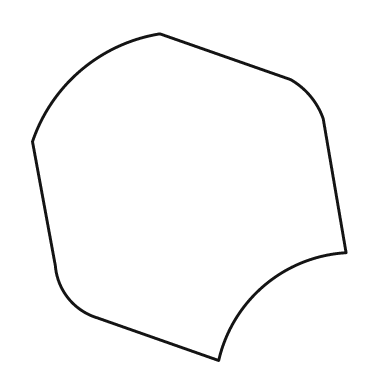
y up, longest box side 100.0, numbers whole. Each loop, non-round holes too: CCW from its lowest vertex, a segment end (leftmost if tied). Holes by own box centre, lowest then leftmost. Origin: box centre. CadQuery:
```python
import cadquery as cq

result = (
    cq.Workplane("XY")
    .moveTo(9.0, -50.0)
    .threePointArc((23.0, -27.0), (48.0, -17.0))
    .lineTo(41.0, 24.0)
    .threePointArc((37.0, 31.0), (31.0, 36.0))
    .lineTo(-9.0, 50.0)
    .threePointArc((-33.0, 39.0), (-48.0, 17.0))
    .lineTo(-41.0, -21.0)
    .threePointArc((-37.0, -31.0), (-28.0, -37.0))
    .close()
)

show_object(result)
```